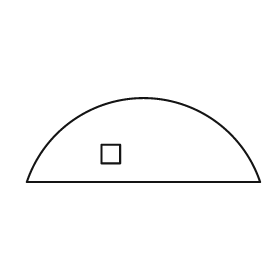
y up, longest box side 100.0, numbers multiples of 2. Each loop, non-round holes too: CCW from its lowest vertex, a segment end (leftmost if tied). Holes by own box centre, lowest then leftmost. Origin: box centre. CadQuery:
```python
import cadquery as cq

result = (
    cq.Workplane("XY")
    .moveTo(-50.0, -18.0)
    .lineTo(50.0, -18.0)
    .threePointArc((0.0, 18.0), (-50.0, -18.0))
    .close()
    .moveTo(-18.0, -10.0)
    .lineTo(-10.0, -10.0)
    .lineTo(-10.0, -2.0)
    .lineTo(-18.0, -2.0)
    .close()
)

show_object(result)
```